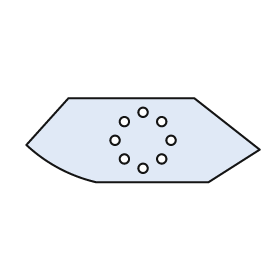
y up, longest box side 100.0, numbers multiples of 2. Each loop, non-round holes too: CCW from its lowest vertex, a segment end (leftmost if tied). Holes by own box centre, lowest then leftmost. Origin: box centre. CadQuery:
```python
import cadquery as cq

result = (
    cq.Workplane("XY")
    .moveTo(-20.0, -18.0)
    .lineTo(28.0, -18.0)
    .lineTo(50.0, -4.0)
    .lineTo(22.0, 18.0)
    .lineTo(-32.0, 18.0)
    .lineTo(-50.0, -2.0)
    .threePointArc((-36.0, -12.0), (-20.0, -18.0))
    .close()
    .moveTo(0.0, -12.0)
    .circle(2.0)
    .moveTo(-8.0, -8.0)
    .circle(2.0)
    .moveTo(8.0, -8.0)
    .circle(2.0)
    .moveTo(-12.0, 0.0)
    .circle(2.0)
    .moveTo(12.0, 0.0)
    .circle(2.0)
    .moveTo(-8.0, 8.0)
    .circle(2.0)
    .moveTo(8.0, 8.0)
    .circle(2.0)
    .moveTo(0.0, 12.0)
    .circle(2.0)
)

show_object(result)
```